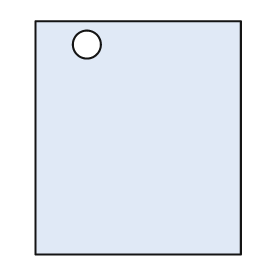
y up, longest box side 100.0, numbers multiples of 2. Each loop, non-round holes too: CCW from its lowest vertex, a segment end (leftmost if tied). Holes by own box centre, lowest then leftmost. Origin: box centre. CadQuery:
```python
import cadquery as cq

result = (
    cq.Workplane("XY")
    .moveTo(-44.0, -50.0)
    .lineTo(44.0, -50.0)
    .lineTo(44.0, 50.0)
    .lineTo(-44.0, 50.0)
    .close()
    .moveTo(-22.0, 40.0)
    .circle(6.0)
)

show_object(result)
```